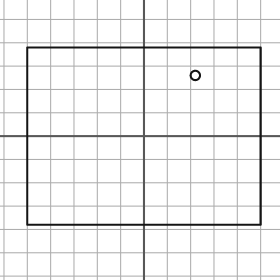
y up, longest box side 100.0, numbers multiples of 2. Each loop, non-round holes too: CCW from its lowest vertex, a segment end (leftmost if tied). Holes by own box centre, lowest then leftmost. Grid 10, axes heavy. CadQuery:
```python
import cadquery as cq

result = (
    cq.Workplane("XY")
    .moveTo(-50.0, -38.0)
    .lineTo(50.0, -38.0)
    .lineTo(50.0, 38.0)
    .lineTo(-50.0, 38.0)
    .close()
    .moveTo(22.0, 26.0)
    .circle(2.0)
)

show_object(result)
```